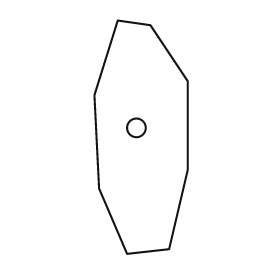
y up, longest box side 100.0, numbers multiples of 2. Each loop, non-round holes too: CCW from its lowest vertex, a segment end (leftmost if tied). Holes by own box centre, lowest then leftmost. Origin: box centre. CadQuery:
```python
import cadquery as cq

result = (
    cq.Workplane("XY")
    .moveTo(-6.0, -50.0)
    .lineTo(12.0, -48.0)
    .lineTo(20.0, -14.0)
    .lineTo(20.0, 24.0)
    .lineTo(4.0, 48.0)
    .lineTo(-10.0, 50.0)
    .lineTo(-20.0, 18.0)
    .lineTo(-18.0, -22.0)
    .close()
    .moveTo(-2.0, 4.0)
    .circle(4.0)
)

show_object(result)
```